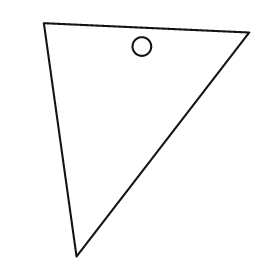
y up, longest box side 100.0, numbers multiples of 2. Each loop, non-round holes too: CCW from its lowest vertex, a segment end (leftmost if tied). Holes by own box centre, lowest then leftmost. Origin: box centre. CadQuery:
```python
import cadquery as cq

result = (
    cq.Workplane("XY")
    .moveTo(-30.0, -50.0)
    .lineTo(44.0, 46.0)
    .lineTo(-44.0, 50.0)
    .close()
    .moveTo(-2.0, 40.0)
    .circle(4.0)
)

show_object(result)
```